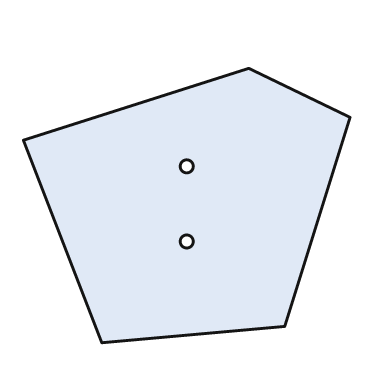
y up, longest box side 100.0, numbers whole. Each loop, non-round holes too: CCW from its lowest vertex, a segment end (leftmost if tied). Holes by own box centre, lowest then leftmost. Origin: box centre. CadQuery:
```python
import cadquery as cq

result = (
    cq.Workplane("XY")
    .moveTo(-26.0, -42.0)
    .lineTo(30.0, -37.0)
    .lineTo(50.0, 27.0)
    .lineTo(19.0, 42.0)
    .lineTo(-50.0, 20.0)
    .close()
    .moveTo(0.0, -11.0)
    .circle(2.0)
    .moveTo(0.0, 12.0)
    .circle(2.0)
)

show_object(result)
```